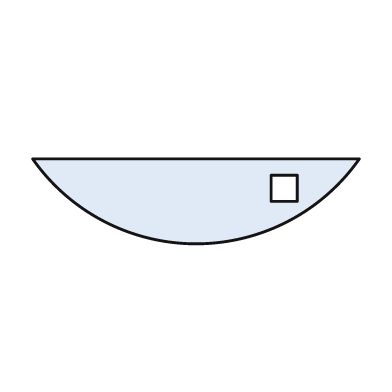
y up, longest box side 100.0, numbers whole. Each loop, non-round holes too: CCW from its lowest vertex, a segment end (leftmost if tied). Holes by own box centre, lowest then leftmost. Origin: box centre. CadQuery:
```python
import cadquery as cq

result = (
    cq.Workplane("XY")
    .moveTo(-50.0, 13.0)
    .threePointArc((0.0, -13.0), (50.0, 13.0))
    .close()
    .moveTo(23.0, 0.0)
    .lineTo(31.0, 0.0)
    .lineTo(31.0, 8.0)
    .lineTo(23.0, 8.0)
    .close()
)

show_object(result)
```